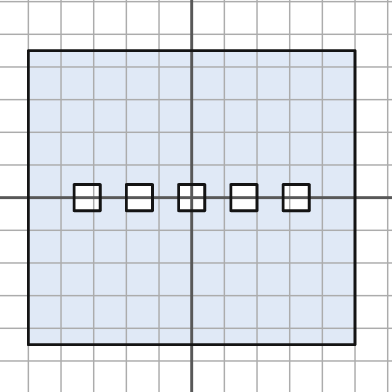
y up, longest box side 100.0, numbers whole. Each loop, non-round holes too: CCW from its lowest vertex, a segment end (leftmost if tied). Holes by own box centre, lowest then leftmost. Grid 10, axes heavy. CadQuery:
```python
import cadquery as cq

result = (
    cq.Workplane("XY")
    .moveTo(-50.0, -45.0)
    .lineTo(50.0, -45.0)
    .lineTo(50.0, 45.0)
    .lineTo(-50.0, 45.0)
    .close()
    .moveTo(-36.0, -4.0)
    .lineTo(-28.0, -4.0)
    .lineTo(-28.0, 4.0)
    .lineTo(-36.0, 4.0)
    .close()
    .moveTo(-20.0, -4.0)
    .lineTo(-12.0, -4.0)
    .lineTo(-12.0, 4.0)
    .lineTo(-20.0, 4.0)
    .close()
    .moveTo(-4.0, -4.0)
    .lineTo(4.0, -4.0)
    .lineTo(4.0, 4.0)
    .lineTo(-4.0, 4.0)
    .close()
    .moveTo(12.0, -4.0)
    .lineTo(20.0, -4.0)
    .lineTo(20.0, 4.0)
    .lineTo(12.0, 4.0)
    .close()
    .moveTo(28.0, -4.0)
    .lineTo(36.0, -4.0)
    .lineTo(36.0, 4.0)
    .lineTo(28.0, 4.0)
    .close()
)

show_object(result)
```